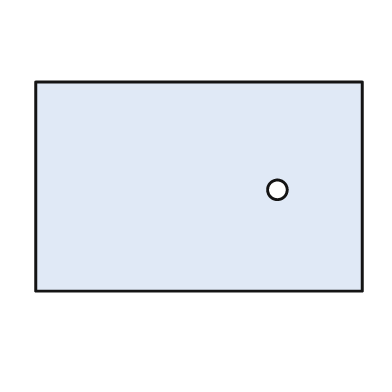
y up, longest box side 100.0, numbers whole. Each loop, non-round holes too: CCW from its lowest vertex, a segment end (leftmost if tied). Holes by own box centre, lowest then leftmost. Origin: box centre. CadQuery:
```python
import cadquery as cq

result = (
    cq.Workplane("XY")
    .moveTo(-50.0, -32.0)
    .lineTo(50.0, -32.0)
    .lineTo(50.0, 32.0)
    .lineTo(-50.0, 32.0)
    .close()
    .moveTo(24.0, -1.0)
    .circle(3.0)
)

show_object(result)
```